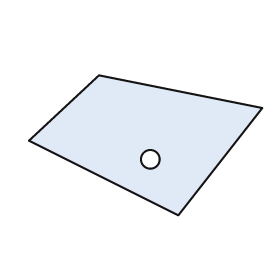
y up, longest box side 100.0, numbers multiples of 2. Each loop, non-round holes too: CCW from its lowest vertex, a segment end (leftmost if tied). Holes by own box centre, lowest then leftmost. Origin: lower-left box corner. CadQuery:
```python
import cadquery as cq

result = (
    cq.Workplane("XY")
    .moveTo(64.0, 0.0)
    .lineTo(100.0, 46.0)
    .lineTo(30.0, 60.0)
    .lineTo(0.0, 32.0)
    .close()
    .moveTo(52.0, 24.0)
    .circle(4.0)
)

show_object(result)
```